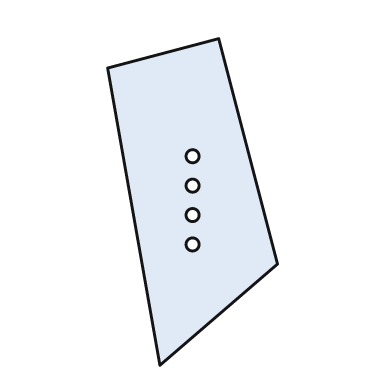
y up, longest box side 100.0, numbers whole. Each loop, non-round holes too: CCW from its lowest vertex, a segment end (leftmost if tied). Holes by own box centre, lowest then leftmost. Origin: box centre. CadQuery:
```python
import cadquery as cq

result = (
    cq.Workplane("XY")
    .moveTo(-10.0, -50.0)
    .lineTo(26.0, -19.0)
    .lineTo(8.0, 50.0)
    .lineTo(-26.0, 41.0)
    .close()
    .moveTo(0.0, -13.0)
    .circle(2.0)
    .moveTo(0.0, -4.0)
    .circle(2.0)
    .moveTo(0.0, 5.0)
    .circle(2.0)
    .moveTo(0.0, 14.0)
    .circle(2.0)
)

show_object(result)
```